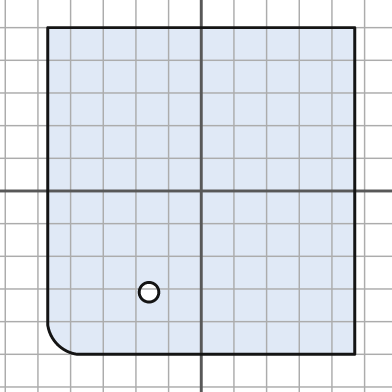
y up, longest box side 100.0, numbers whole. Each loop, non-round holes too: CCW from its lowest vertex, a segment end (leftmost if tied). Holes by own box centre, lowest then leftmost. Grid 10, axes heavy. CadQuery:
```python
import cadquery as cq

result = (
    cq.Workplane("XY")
    .moveTo(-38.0, -50.0)
    .lineTo(47.0, -50.0)
    .lineTo(47.0, 50.0)
    .lineTo(-47.0, 50.0)
    .lineTo(-47.0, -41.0)
    .threePointArc((-44.0, -47.0), (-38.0, -50.0))
    .close()
    .moveTo(-16.0, -31.0)
    .circle(3.0)
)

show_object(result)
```